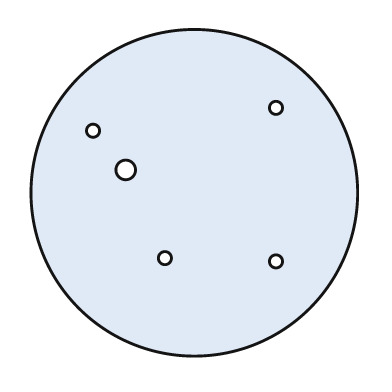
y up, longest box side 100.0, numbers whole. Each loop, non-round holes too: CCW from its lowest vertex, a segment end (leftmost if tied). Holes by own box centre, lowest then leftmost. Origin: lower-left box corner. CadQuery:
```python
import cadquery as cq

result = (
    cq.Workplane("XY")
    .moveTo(50.0, 50.0)
    .circle(50.0)
    .moveTo(75.0, 29.0)
    .circle(2.0)
    .moveTo(41.0, 30.0)
    .circle(2.0)
    .moveTo(29.0, 57.0)
    .circle(3.0)
    .moveTo(19.0, 69.0)
    .circle(2.0)
    .moveTo(75.0, 76.0)
    .circle(2.0)
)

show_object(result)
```